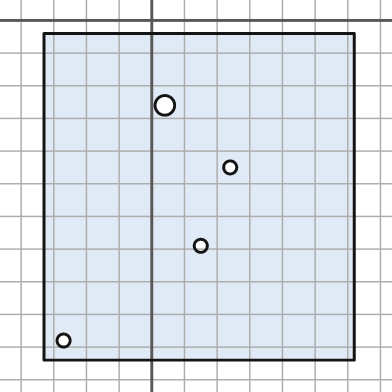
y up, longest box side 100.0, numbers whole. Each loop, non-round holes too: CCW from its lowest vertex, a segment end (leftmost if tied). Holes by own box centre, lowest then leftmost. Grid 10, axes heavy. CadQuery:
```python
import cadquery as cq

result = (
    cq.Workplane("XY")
    .moveTo(-33.0, -104.0)
    .lineTo(62.0, -104.0)
    .lineTo(62.0, -4.0)
    .lineTo(-33.0, -4.0)
    .close()
    .moveTo(-27.0, -98.0)
    .circle(2.0)
    .moveTo(15.0, -69.0)
    .circle(2.0)
    .moveTo(24.0, -45.0)
    .circle(2.0)
    .moveTo(4.0, -26.0)
    .circle(3.0)
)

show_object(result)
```